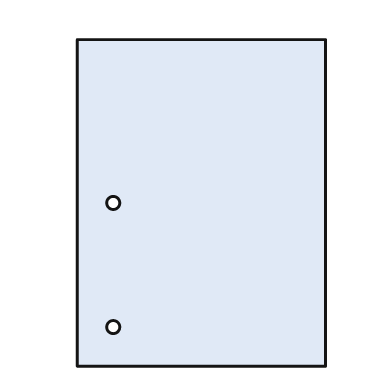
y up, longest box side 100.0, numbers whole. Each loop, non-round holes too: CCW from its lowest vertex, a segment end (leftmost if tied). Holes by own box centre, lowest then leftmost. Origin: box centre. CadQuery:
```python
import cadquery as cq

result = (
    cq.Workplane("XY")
    .moveTo(-38.0, -50.0)
    .lineTo(38.0, -50.0)
    .lineTo(38.0, 50.0)
    .lineTo(-38.0, 50.0)
    .close()
    .moveTo(-27.0, -38.0)
    .circle(2.0)
    .moveTo(-27.0, 0.0)
    .circle(2.0)
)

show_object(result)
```